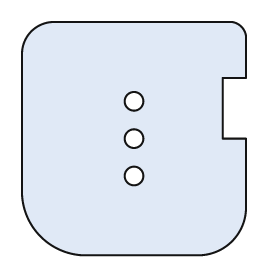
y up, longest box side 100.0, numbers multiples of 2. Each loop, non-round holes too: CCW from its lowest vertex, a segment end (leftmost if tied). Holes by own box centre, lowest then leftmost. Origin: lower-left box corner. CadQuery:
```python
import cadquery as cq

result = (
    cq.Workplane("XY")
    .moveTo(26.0, 0.0)
    .lineTo(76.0, 0.0)
    .threePointArc((90.0, 6.0), (96.0, 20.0))
    .lineTo(96.0, 50.0)
    .lineTo(86.0, 50.0)
    .lineTo(86.0, 76.0)
    .lineTo(96.0, 76.0)
    .lineTo(96.0, 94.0)
    .threePointArc((94.0, 98.0), (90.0, 100.0))
    .lineTo(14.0, 100.0)
    .threePointArc((4.0, 96.0), (0.0, 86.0))
    .lineTo(0.0, 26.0)
    .threePointArc((8.0, 8.0), (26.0, 0.0))
    .close()
    .moveTo(48.0, 34.0)
    .circle(4.0)
    .moveTo(48.0, 50.0)
    .circle(4.0)
    .moveTo(48.0, 66.0)
    .circle(4.0)
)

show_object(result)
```